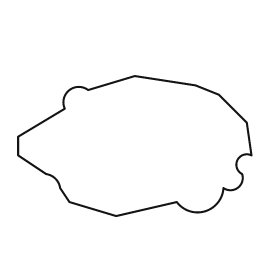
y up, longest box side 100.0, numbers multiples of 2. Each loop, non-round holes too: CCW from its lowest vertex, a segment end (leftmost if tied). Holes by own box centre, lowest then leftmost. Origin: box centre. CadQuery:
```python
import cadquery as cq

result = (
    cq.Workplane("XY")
    .moveTo(-8.0, -30.0)
    .lineTo(18.0, -24.0)
    .threePointArc((30.0, -28.0), (38.0, -18.0))
    .threePointArc((44.0, -18.0), (46.0, -12.0))
    .threePointArc((44.0, -6.0), (50.0, -4.0))
    .lineTo(48.0, 10.0)
    .lineTo(36.0, 22.0)
    .lineTo(26.0, 26.0)
    .lineTo(0.0, 30.0)
    .lineTo(-20.0, 24.0)
    .threePointArc((-28.0, 24.0), (-30.0, 16.0))
    .lineTo(-50.0, 4.0)
    .lineTo(-50.0, -4.0)
    .lineTo(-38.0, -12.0)
    .threePointArc((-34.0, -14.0), (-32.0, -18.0))
    .lineTo(-28.0, -24.0)
    .close()
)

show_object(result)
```